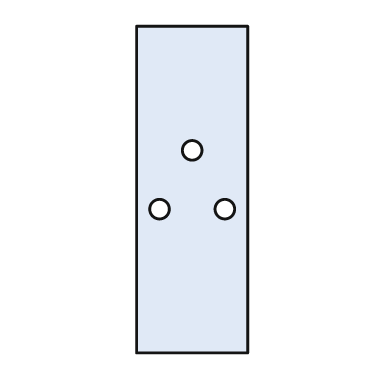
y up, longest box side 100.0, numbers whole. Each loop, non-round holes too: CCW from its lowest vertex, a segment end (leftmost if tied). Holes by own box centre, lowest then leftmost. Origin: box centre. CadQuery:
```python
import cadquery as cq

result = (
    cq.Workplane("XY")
    .moveTo(-17.0, -50.0)
    .lineTo(17.0, -50.0)
    .lineTo(17.0, 50.0)
    .lineTo(-17.0, 50.0)
    .close()
    .moveTo(-10.0, -6.0)
    .circle(3.0)
    .moveTo(10.0, -6.0)
    .circle(3.0)
    .moveTo(0.0, 12.0)
    .circle(3.0)
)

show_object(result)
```